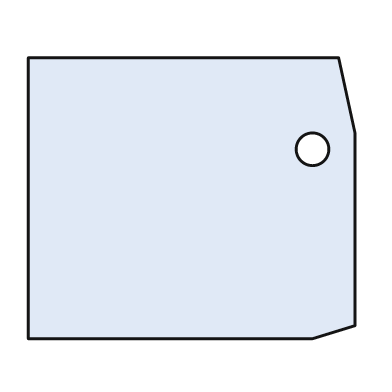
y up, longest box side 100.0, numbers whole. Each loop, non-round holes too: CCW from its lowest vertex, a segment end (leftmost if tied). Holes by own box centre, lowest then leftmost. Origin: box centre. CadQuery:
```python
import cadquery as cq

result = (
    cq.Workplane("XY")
    .moveTo(-50.0, -43.0)
    .lineTo(37.0, -43.0)
    .lineTo(50.0, -39.0)
    .lineTo(50.0, 20.0)
    .lineTo(45.0, 43.0)
    .lineTo(-50.0, 43.0)
    .close()
    .moveTo(37.0, 15.0)
    .circle(5.0)
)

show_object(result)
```